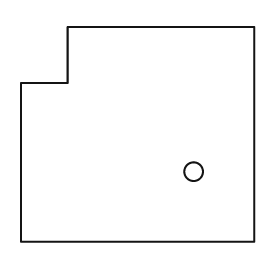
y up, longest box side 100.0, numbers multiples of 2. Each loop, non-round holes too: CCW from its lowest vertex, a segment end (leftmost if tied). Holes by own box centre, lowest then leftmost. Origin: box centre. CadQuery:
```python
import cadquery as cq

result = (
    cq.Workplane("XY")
    .moveTo(-50.0, -46.0)
    .lineTo(50.0, -46.0)
    .lineTo(50.0, 46.0)
    .lineTo(-30.0, 46.0)
    .lineTo(-30.0, 22.0)
    .lineTo(-50.0, 22.0)
    .close()
    .moveTo(24.0, -16.0)
    .circle(4.0)
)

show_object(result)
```